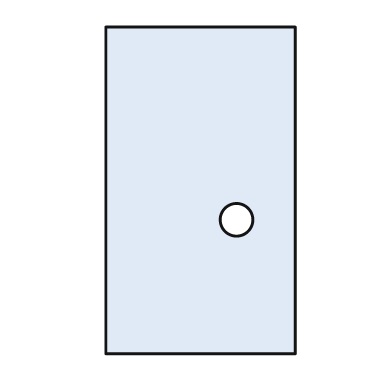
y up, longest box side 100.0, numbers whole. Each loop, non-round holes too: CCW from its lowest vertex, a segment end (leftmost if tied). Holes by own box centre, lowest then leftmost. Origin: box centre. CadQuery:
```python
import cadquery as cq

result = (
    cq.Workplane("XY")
    .moveTo(-29.0, -50.0)
    .lineTo(29.0, -50.0)
    .lineTo(29.0, 50.0)
    .lineTo(-29.0, 50.0)
    .close()
    .moveTo(11.0, -9.0)
    .circle(5.0)
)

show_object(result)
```